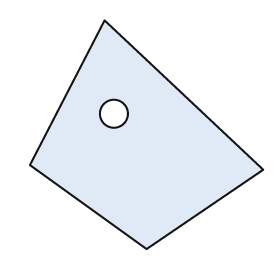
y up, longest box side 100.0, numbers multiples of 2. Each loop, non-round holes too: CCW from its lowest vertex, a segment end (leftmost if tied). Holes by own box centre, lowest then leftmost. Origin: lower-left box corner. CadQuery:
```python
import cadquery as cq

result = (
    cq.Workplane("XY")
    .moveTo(50.0, 0.0)
    .lineTo(100.0, 34.0)
    .lineTo(32.0, 98.0)
    .lineTo(0.0, 36.0)
    .close()
    .moveTo(36.0, 58.0)
    .circle(6.0)
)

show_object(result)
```